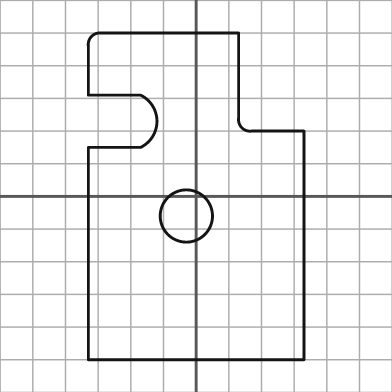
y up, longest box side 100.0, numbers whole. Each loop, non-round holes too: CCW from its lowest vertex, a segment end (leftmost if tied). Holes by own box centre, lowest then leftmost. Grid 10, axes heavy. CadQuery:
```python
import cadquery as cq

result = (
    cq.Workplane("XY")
    .moveTo(-33.0, -50.0)
    .lineTo(33.0, -50.0)
    .lineTo(33.0, 20.0)
    .lineTo(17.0, 20.0)
    .threePointArc((14.0, 21.0), (13.0, 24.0))
    .lineTo(13.0, 50.0)
    .lineTo(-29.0, 50.0)
    .threePointArc((-32.0, 49.0), (-33.0, 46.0))
    .lineTo(-33.0, 31.0)
    .lineTo(-17.0, 31.0)
    .threePointArc((-12.0, 23.0), (-17.0, 15.0))
    .lineTo(-33.0, 15.0)
    .close()
    .moveTo(-3.0, -6.0)
    .circle(8.0)
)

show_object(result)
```